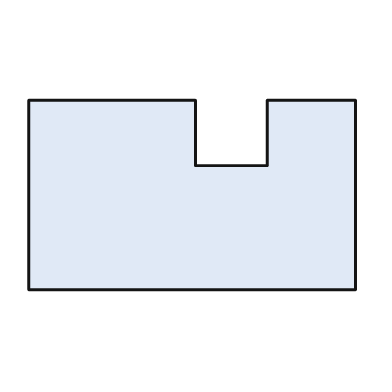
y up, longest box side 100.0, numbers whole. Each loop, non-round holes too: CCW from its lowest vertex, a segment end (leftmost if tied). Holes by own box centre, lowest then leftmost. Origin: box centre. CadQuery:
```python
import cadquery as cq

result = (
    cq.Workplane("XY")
    .moveTo(-50.0, -29.0)
    .lineTo(50.0, -29.0)
    .lineTo(50.0, 29.0)
    .lineTo(23.0, 29.0)
    .lineTo(23.0, 9.0)
    .lineTo(1.0, 9.0)
    .lineTo(1.0, 29.0)
    .lineTo(-50.0, 29.0)
    .close()
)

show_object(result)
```